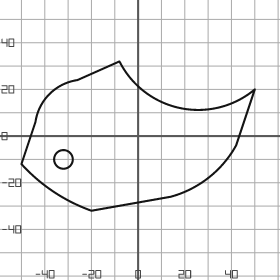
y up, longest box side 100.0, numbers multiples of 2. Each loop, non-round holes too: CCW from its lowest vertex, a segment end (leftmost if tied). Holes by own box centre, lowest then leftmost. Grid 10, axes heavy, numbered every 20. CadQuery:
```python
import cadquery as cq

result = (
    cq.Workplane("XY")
    .moveTo(-20.0, -32.0)
    .lineTo(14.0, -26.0)
    .threePointArc((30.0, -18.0), (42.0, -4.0))
    .lineTo(50.0, 20.0)
    .threePointArc((18.0, 12.0), (-8.0, 32.0))
    .lineTo(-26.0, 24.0)
    .threePointArc((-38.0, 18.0), (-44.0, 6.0))
    .lineTo(-50.0, -12.0)
    .threePointArc((-36.0, -24.0), (-20.0, -32.0))
    .close()
    .moveTo(-32.0, -10.0)
    .circle(4.0)
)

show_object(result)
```